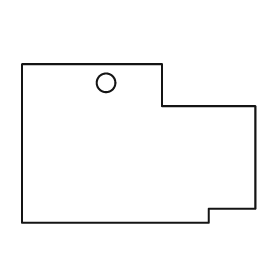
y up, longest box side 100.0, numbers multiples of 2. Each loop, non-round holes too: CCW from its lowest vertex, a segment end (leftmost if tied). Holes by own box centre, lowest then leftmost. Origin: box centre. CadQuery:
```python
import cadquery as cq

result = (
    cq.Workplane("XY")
    .moveTo(-50.0, -34.0)
    .lineTo(30.0, -34.0)
    .lineTo(30.0, -28.0)
    .lineTo(50.0, -28.0)
    .lineTo(50.0, 16.0)
    .lineTo(10.0, 16.0)
    .lineTo(10.0, 34.0)
    .lineTo(-50.0, 34.0)
    .close()
    .moveTo(-14.0, 26.0)
    .circle(4.0)
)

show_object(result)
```